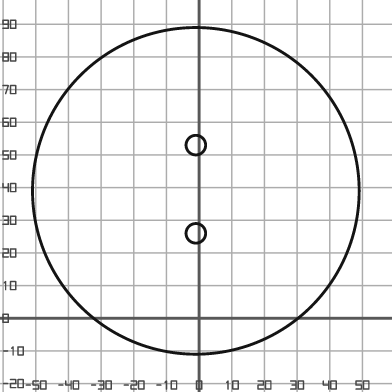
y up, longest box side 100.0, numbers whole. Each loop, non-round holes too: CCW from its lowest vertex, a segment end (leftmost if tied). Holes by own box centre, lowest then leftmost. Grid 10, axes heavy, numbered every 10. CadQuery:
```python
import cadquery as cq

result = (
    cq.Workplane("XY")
    .moveTo(-1.0, 39.0)
    .circle(50.0)
    .moveTo(-1.0, 26.0)
    .circle(3.0)
    .moveTo(-1.0, 53.0)
    .circle(3.0)
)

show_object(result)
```